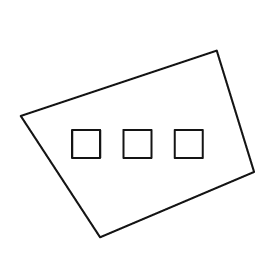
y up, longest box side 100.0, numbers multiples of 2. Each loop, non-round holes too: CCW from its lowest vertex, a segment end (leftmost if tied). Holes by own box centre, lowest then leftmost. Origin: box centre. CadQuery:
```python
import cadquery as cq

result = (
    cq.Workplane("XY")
    .moveTo(-16.0, -40.0)
    .lineTo(50.0, -12.0)
    .lineTo(34.0, 40.0)
    .lineTo(-50.0, 12.0)
    .close()
    .moveTo(-28.0, -6.0)
    .lineTo(-16.0, -6.0)
    .lineTo(-16.0, 6.0)
    .lineTo(-28.0, 6.0)
    .close()
    .moveTo(-6.0, -6.0)
    .lineTo(6.0, -6.0)
    .lineTo(6.0, 6.0)
    .lineTo(-6.0, 6.0)
    .close()
    .moveTo(16.0, -6.0)
    .lineTo(28.0, -6.0)
    .lineTo(28.0, 6.0)
    .lineTo(16.0, 6.0)
    .close()
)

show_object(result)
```